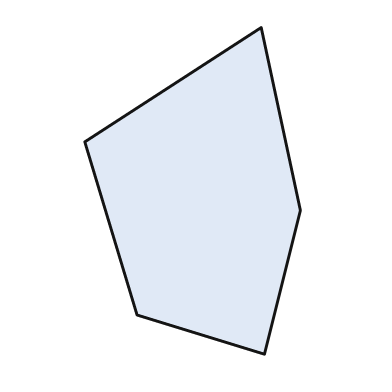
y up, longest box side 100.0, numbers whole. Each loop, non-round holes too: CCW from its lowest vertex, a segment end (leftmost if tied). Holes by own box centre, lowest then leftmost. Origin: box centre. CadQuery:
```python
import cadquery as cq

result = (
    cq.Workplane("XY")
    .moveTo(22.0, -50.0)
    .lineTo(33.0, -6.0)
    .lineTo(21.0, 50.0)
    .lineTo(-33.0, 15.0)
    .lineTo(-17.0, -38.0)
    .close()
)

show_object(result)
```